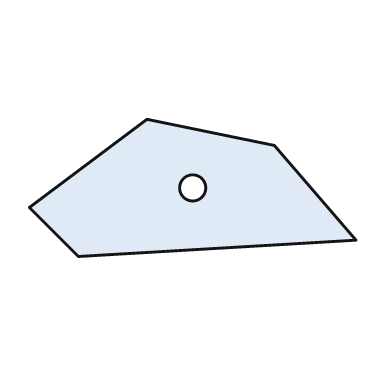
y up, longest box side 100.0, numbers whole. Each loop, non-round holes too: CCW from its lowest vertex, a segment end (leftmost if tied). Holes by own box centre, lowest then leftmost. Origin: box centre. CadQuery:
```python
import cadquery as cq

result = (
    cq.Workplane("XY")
    .moveTo(-35.0, -21.0)
    .lineTo(50.0, -16.0)
    .lineTo(25.0, 13.0)
    .lineTo(-14.0, 21.0)
    .lineTo(-50.0, -6.0)
    .close()
    .moveTo(0.0, 0.0)
    .circle(4.0)
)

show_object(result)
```